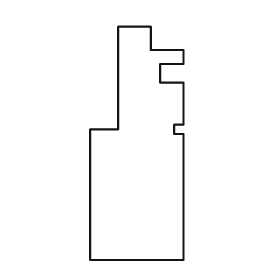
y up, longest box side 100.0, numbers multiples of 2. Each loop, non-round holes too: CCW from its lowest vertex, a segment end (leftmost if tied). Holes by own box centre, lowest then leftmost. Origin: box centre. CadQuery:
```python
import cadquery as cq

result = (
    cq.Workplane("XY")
    .moveTo(-20.0, -50.0)
    .lineTo(20.0, -50.0)
    .lineTo(20.0, 4.0)
    .lineTo(16.0, 4.0)
    .lineTo(16.0, 8.0)
    .lineTo(20.0, 8.0)
    .lineTo(20.0, 26.0)
    .lineTo(10.0, 26.0)
    .lineTo(10.0, 34.0)
    .lineTo(20.0, 34.0)
    .lineTo(20.0, 40.0)
    .lineTo(6.0, 40.0)
    .lineTo(6.0, 50.0)
    .lineTo(-8.0, 50.0)
    .lineTo(-8.0, 6.0)
    .lineTo(-20.0, 6.0)
    .close()
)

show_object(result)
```